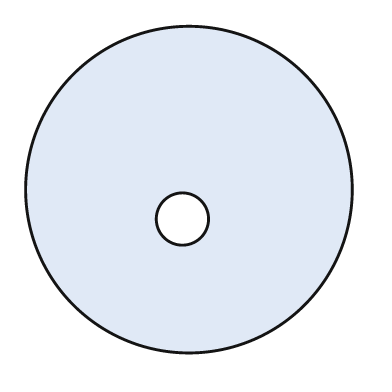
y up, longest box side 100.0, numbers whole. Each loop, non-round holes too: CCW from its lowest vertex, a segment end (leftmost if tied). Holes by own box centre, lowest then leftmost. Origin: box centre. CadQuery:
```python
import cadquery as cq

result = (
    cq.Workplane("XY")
    .moveTo(0.0, 0.0)
    .circle(50.0)
    .moveTo(-2.0, -9.0)
    .circle(8.0)
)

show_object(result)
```